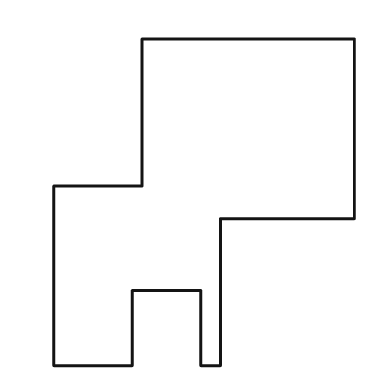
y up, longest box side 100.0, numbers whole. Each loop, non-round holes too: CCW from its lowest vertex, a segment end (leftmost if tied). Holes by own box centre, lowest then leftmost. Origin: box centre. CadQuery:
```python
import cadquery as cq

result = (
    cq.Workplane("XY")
    .moveTo(-46.0, -50.0)
    .lineTo(-22.0, -50.0)
    .lineTo(-22.0, -27.0)
    .lineTo(-1.0, -27.0)
    .lineTo(-1.0, -50.0)
    .lineTo(5.0, -50.0)
    .lineTo(5.0, -5.0)
    .lineTo(46.0, -5.0)
    .lineTo(46.0, 50.0)
    .lineTo(-19.0, 50.0)
    .lineTo(-19.0, 5.0)
    .lineTo(-46.0, 5.0)
    .close()
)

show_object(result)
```